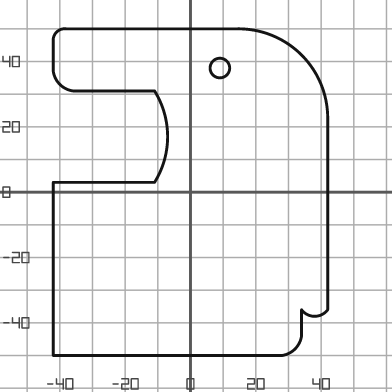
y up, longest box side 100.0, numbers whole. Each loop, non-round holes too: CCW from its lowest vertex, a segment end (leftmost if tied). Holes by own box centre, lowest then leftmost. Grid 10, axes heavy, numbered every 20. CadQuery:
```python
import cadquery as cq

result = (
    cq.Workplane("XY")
    .moveTo(-42.0, -50.0)
    .lineTo(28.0, -50.0)
    .threePointArc((32.0, -48.0), (34.0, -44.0))
    .lineTo(34.0, -36.0)
    .threePointArc((38.0, -38.0), (42.0, -36.0))
    .lineTo(42.0, 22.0)
    .threePointArc((34.0, 42.0), (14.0, 50.0))
    .lineTo(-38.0, 50.0)
    .threePointArc((-41.0, 49.0), (-42.0, 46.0))
    .lineTo(-42.0, 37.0)
    .threePointArc((-40.0, 33.0), (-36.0, 31.0))
    .lineTo(-11.0, 31.0)
    .threePointArc((-7.0, 17.0), (-11.0, 3.0))
    .lineTo(-42.0, 3.0)
    .close()
    .moveTo(9.0, 38.0)
    .circle(3.0)
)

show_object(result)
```